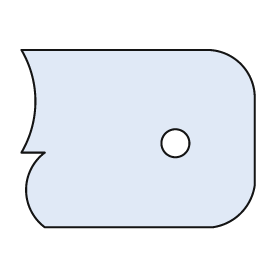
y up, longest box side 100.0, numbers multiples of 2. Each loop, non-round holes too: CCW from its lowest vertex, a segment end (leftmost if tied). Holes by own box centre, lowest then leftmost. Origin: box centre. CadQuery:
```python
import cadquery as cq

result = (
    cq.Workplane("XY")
    .moveTo(-40.0, -38.0)
    .lineTo(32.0, -38.0)
    .threePointArc((44.0, -32.0), (50.0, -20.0))
    .lineTo(50.0, 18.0)
    .threePointArc((44.0, 32.0), (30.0, 38.0))
    .lineTo(-50.0, 38.0)
    .threePointArc((-44.0, 16.0), (-50.0, -6.0))
    .lineTo(-40.0, -6.0)
    .threePointArc((-48.0, -22.0), (-40.0, -38.0))
    .close()
    .moveTo(16.0, -2.0)
    .circle(6.0)
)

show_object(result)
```